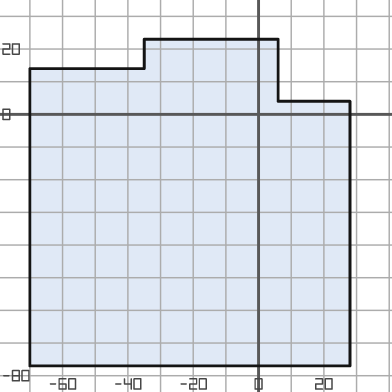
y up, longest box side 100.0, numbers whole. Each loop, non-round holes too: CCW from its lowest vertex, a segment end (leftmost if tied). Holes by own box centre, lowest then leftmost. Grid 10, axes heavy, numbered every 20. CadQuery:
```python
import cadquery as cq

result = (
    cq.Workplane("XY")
    .moveTo(-70.0, -77.0)
    .lineTo(28.0, -77.0)
    .lineTo(28.0, 4.0)
    .lineTo(6.0, 4.0)
    .lineTo(6.0, 23.0)
    .lineTo(-35.0, 23.0)
    .lineTo(-35.0, 14.0)
    .lineTo(-70.0, 14.0)
    .close()
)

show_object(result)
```